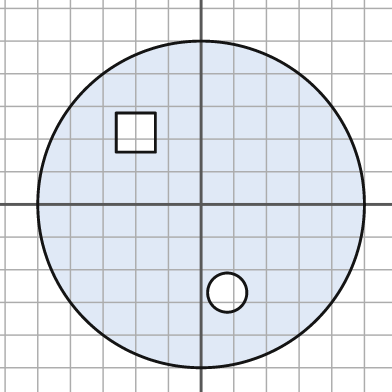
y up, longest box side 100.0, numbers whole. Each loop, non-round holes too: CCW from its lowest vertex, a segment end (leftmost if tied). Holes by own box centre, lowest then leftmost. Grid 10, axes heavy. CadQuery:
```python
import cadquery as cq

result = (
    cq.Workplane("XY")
    .moveTo(0.0, 0.0)
    .circle(50.0)
    .moveTo(8.0, -27.0)
    .circle(6.0)
    .moveTo(-26.0, 16.0)
    .lineTo(-14.0, 16.0)
    .lineTo(-14.0, 28.0)
    .lineTo(-26.0, 28.0)
    .close()
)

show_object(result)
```